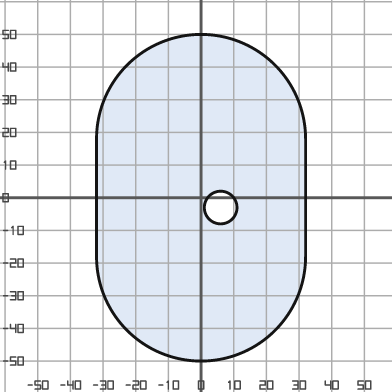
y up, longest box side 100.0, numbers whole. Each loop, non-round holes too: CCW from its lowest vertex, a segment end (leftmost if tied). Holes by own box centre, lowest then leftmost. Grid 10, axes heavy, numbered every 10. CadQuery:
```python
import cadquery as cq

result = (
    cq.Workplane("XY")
    .moveTo(-32.0, -18.0)
    .threePointArc((0.0, -50.0), (32.0, -18.0))
    .lineTo(32.0, 18.0)
    .threePointArc((0.0, 50.0), (-32.0, 18.0))
    .close()
    .moveTo(6.0, -3.0)
    .circle(5.0)
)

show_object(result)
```